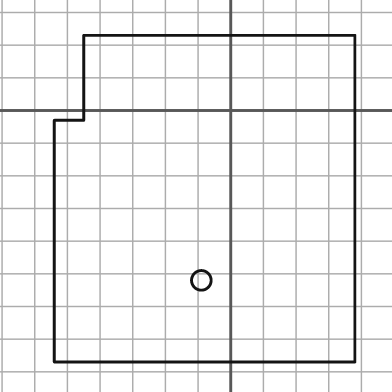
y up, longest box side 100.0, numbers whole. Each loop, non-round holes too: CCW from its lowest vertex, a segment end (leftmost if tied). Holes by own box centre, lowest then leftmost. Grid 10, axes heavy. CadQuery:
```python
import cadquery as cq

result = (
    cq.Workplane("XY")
    .moveTo(-54.0, -77.0)
    .lineTo(38.0, -77.0)
    .lineTo(38.0, 23.0)
    .lineTo(-45.0, 23.0)
    .lineTo(-45.0, -3.0)
    .lineTo(-54.0, -3.0)
    .close()
    .moveTo(-9.0, -52.0)
    .circle(3.0)
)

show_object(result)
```